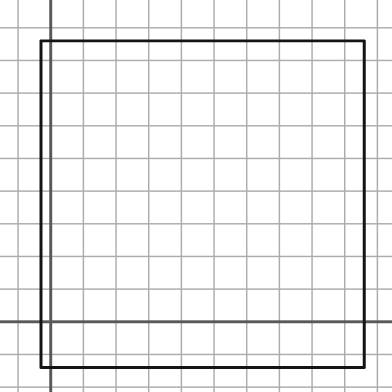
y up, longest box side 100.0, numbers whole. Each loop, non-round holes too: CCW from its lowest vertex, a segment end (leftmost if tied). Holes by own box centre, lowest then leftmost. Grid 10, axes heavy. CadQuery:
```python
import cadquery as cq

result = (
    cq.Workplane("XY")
    .moveTo(-3.0, -14.0)
    .lineTo(96.0, -14.0)
    .lineTo(96.0, 86.0)
    .lineTo(-3.0, 86.0)
    .close()
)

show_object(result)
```